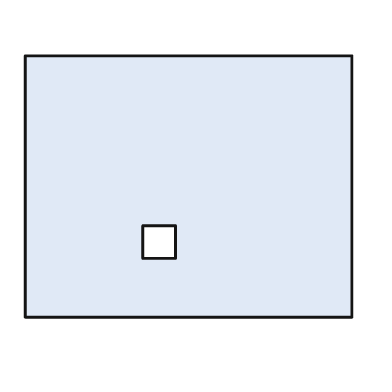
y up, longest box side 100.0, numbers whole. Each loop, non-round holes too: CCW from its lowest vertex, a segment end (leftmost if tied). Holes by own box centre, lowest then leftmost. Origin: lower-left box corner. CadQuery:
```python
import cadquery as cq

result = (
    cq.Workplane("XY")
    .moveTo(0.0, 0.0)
    .lineTo(100.0, 0.0)
    .lineTo(100.0, 80.0)
    .lineTo(0.0, 80.0)
    .close()
    .moveTo(36.0, 18.0)
    .lineTo(46.0, 18.0)
    .lineTo(46.0, 28.0)
    .lineTo(36.0, 28.0)
    .close()
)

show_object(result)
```